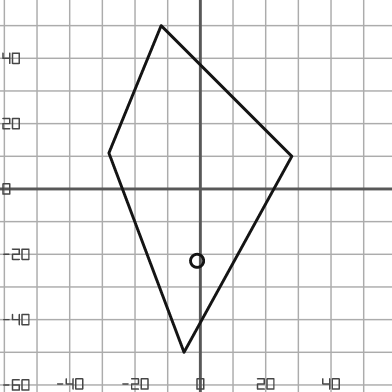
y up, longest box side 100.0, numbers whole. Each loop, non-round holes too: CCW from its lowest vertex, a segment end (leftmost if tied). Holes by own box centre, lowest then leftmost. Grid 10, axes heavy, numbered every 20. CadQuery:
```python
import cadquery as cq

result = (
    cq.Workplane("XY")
    .moveTo(-5.0, -50.0)
    .lineTo(28.0, 10.0)
    .lineTo(-12.0, 50.0)
    .lineTo(-28.0, 11.0)
    .close()
    .moveTo(-1.0, -22.0)
    .circle(2.0)
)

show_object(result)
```